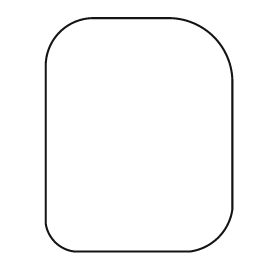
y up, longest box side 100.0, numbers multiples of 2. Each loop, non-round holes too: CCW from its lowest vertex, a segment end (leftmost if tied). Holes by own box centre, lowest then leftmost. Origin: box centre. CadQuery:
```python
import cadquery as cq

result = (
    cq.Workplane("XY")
    .moveTo(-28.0, -50.0)
    .lineTo(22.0, -50.0)
    .threePointArc((34.0, -44.0), (40.0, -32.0))
    .lineTo(40.0, 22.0)
    .threePointArc((32.0, 42.0), (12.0, 50.0))
    .lineTo(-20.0, 50.0)
    .threePointArc((-34.0, 44.0), (-40.0, 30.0))
    .lineTo(-40.0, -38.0)
    .threePointArc((-36.0, -46.0), (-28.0, -50.0))
    .close()
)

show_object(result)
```